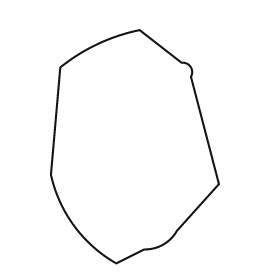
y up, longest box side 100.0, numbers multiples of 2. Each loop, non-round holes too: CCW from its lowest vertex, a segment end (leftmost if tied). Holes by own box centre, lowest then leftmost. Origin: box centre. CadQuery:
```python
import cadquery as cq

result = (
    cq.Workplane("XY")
    .moveTo(-8.0, -50.0)
    .lineTo(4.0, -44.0)
    .threePointArc((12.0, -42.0), (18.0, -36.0))
    .lineTo(36.0, -16.0)
    .lineTo(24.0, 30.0)
    .threePointArc((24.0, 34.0), (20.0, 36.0))
    .lineTo(2.0, 50.0)
    .threePointArc((-16.0, 44.0), (-32.0, 34.0))
    .lineTo(-36.0, -12.0)
    .threePointArc((-26.0, -34.0), (-8.0, -50.0))
    .close()
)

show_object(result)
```